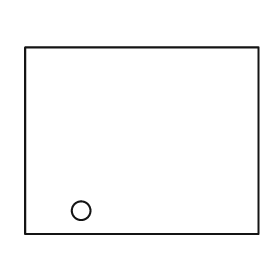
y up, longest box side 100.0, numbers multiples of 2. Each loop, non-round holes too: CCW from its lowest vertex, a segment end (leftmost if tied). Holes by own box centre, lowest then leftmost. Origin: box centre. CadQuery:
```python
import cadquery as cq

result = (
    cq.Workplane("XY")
    .moveTo(-50.0, -40.0)
    .lineTo(50.0, -40.0)
    .lineTo(50.0, 40.0)
    .lineTo(-50.0, 40.0)
    .close()
    .moveTo(-26.0, -30.0)
    .circle(4.0)
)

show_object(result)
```